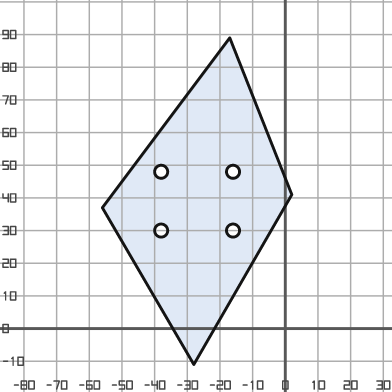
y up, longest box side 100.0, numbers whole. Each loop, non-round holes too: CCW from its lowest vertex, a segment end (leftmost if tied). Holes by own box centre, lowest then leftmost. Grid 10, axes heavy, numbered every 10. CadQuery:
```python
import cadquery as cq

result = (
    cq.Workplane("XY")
    .moveTo(-28.0, -11.0)
    .lineTo(2.0, 41.0)
    .lineTo(-17.0, 89.0)
    .lineTo(-56.0, 37.0)
    .close()
    .moveTo(-38.0, 30.0)
    .circle(2.0)
    .moveTo(-16.0, 30.0)
    .circle(2.0)
    .moveTo(-38.0, 48.0)
    .circle(2.0)
    .moveTo(-16.0, 48.0)
    .circle(2.0)
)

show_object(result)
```